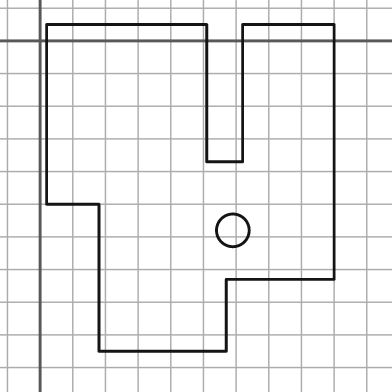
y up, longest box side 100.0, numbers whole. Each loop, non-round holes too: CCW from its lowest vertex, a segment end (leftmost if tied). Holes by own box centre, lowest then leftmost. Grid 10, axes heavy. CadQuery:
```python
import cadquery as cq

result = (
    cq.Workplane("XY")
    .moveTo(18.0, -95.0)
    .lineTo(57.0, -95.0)
    .lineTo(57.0, -73.0)
    .lineTo(90.0, -73.0)
    .lineTo(90.0, 5.0)
    .lineTo(62.0, 5.0)
    .lineTo(62.0, -37.0)
    .lineTo(51.0, -37.0)
    .lineTo(51.0, 5.0)
    .lineTo(2.0, 5.0)
    .lineTo(2.0, -50.0)
    .lineTo(18.0, -50.0)
    .close()
    .moveTo(59.0, -58.0)
    .circle(5.0)
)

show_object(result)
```